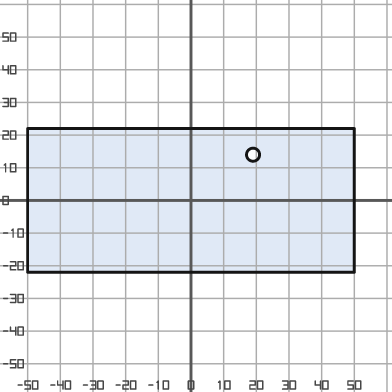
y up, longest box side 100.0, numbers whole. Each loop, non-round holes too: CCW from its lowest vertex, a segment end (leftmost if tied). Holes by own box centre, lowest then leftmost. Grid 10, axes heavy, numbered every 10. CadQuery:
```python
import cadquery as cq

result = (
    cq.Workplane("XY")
    .moveTo(-50.0, -22.0)
    .lineTo(50.0, -22.0)
    .lineTo(50.0, 22.0)
    .lineTo(-50.0, 22.0)
    .close()
    .moveTo(19.0, 14.0)
    .circle(2.0)
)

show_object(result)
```